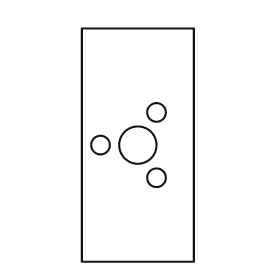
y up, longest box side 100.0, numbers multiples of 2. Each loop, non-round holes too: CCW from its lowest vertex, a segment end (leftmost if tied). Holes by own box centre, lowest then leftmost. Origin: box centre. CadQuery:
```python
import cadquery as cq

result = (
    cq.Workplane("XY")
    .moveTo(-24.0, -50.0)
    .lineTo(24.0, -50.0)
    .lineTo(24.0, 50.0)
    .lineTo(-24.0, 50.0)
    .close()
    .moveTo(8.0, -14.0)
    .circle(4.0)
    .moveTo(-16.0, 0.0)
    .circle(4.0)
    .moveTo(0.0, 0.0)
    .circle(8.0)
    .moveTo(8.0, 14.0)
    .circle(4.0)
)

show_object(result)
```